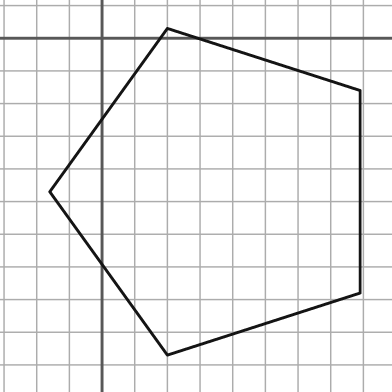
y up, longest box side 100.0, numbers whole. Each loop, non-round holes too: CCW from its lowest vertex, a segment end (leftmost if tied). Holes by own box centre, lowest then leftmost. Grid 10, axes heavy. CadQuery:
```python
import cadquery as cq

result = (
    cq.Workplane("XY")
    .moveTo(20.0, -97.0)
    .lineTo(79.0, -78.0)
    .lineTo(79.0, -16.0)
    .lineTo(20.0, 3.0)
    .lineTo(-16.0, -47.0)
    .close()
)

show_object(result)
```